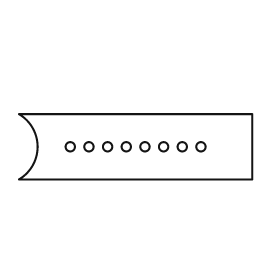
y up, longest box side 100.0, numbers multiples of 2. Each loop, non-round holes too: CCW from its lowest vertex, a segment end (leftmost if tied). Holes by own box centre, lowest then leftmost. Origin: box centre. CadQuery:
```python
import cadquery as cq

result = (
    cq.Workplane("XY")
    .moveTo(-50.0, -14.0)
    .lineTo(50.0, -14.0)
    .lineTo(50.0, 14.0)
    .lineTo(-50.0, 14.0)
    .threePointArc((-42.0, 0.0), (-50.0, -14.0))
    .close()
    .moveTo(-28.0, 0.0)
    .circle(2.0)
    .moveTo(-20.0, 0.0)
    .circle(2.0)
    .moveTo(-12.0, 0.0)
    .circle(2.0)
    .moveTo(-4.0, 0.0)
    .circle(2.0)
    .moveTo(4.0, 0.0)
    .circle(2.0)
    .moveTo(12.0, 0.0)
    .circle(2.0)
    .moveTo(20.0, 0.0)
    .circle(2.0)
    .moveTo(28.0, 0.0)
    .circle(2.0)
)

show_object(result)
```